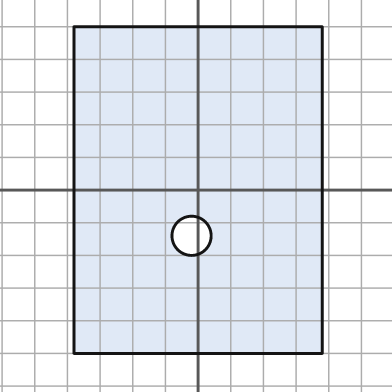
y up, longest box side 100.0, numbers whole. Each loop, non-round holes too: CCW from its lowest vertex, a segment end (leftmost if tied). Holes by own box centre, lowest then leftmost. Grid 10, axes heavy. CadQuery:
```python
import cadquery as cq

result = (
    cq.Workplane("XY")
    .moveTo(-38.0, -50.0)
    .lineTo(38.0, -50.0)
    .lineTo(38.0, 50.0)
    .lineTo(-38.0, 50.0)
    .close()
    .moveTo(-2.0, -14.0)
    .circle(6.0)
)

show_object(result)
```